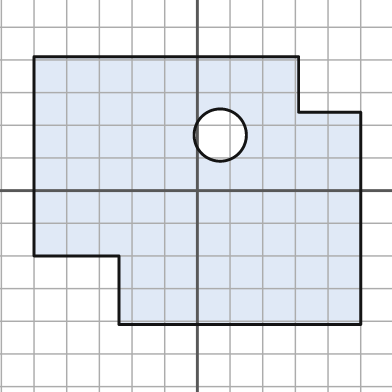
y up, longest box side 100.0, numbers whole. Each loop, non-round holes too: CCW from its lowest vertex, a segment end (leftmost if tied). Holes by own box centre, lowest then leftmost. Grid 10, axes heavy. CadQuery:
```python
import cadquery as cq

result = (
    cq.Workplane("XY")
    .moveTo(-24.0, -41.0)
    .lineTo(50.0, -41.0)
    .lineTo(50.0, 24.0)
    .lineTo(31.0, 24.0)
    .lineTo(31.0, 41.0)
    .lineTo(-50.0, 41.0)
    .lineTo(-50.0, -20.0)
    .lineTo(-24.0, -20.0)
    .close()
    .moveTo(7.0, 17.0)
    .circle(8.0)
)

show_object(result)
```